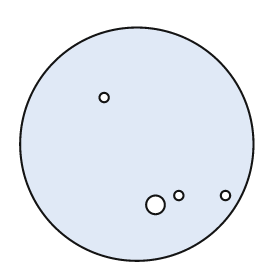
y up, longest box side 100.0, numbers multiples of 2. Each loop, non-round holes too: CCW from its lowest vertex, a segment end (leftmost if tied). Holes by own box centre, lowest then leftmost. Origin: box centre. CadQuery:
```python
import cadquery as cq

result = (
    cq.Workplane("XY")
    .moveTo(0.0, 0.0)
    .circle(50.0)
    .moveTo(8.0, -26.0)
    .circle(4.0)
    .moveTo(18.0, -22.0)
    .circle(2.0)
    .moveTo(38.0, -22.0)
    .circle(2.0)
    .moveTo(-14.0, 20.0)
    .circle(2.0)
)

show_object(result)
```